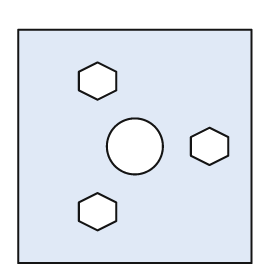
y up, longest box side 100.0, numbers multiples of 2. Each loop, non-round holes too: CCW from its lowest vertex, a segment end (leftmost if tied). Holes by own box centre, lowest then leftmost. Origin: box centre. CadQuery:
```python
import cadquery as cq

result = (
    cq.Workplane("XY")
    .moveTo(-50.0, -50.0)
    .lineTo(50.0, -50.0)
    .lineTo(50.0, 50.0)
    .lineTo(-50.0, 50.0)
    .close()
    .moveTo(-16.0, -36.0)
    .lineTo(-8.0, -32.0)
    .lineTo(-8.0, -24.0)
    .lineTo(-16.0, -20.0)
    .lineTo(-24.0, -24.0)
    .lineTo(-24.0, -32.0)
    .close()
    .moveTo(0.0, 0.0)
    .circle(12.0)
    .moveTo(32.0, -8.0)
    .lineTo(40.0, -4.0)
    .lineTo(40.0, 4.0)
    .lineTo(32.0, 8.0)
    .lineTo(24.0, 4.0)
    .lineTo(24.0, -4.0)
    .close()
    .moveTo(-16.0, 20.0)
    .lineTo(-8.0, 24.0)
    .lineTo(-8.0, 32.0)
    .lineTo(-16.0, 36.0)
    .lineTo(-24.0, 32.0)
    .lineTo(-24.0, 24.0)
    .close()
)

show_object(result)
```